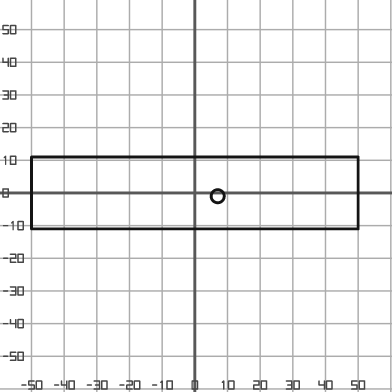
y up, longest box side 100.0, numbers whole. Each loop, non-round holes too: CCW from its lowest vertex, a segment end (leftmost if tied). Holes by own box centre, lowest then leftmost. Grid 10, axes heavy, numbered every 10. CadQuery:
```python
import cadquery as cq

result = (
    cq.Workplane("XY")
    .moveTo(-50.0, -11.0)
    .lineTo(50.0, -11.0)
    .lineTo(50.0, 11.0)
    .lineTo(-50.0, 11.0)
    .close()
    .moveTo(7.0, -1.0)
    .circle(2.0)
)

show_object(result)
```